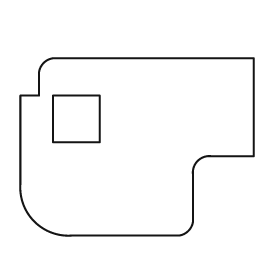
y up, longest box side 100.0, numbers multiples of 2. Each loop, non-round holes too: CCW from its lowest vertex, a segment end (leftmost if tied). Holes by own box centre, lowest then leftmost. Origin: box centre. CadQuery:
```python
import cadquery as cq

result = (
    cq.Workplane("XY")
    .moveTo(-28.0, -38.0)
    .lineTo(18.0, -38.0)
    .threePointArc((22.0, -36.0), (24.0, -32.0))
    .lineTo(24.0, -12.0)
    .threePointArc((26.0, -6.0), (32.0, -4.0))
    .lineTo(50.0, -4.0)
    .lineTo(50.0, 38.0)
    .lineTo(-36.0, 38.0)
    .threePointArc((-40.0, 36.0), (-42.0, 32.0))
    .lineTo(-42.0, 22.0)
    .lineTo(-50.0, 22.0)
    .lineTo(-50.0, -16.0)
    .threePointArc((-44.0, -32.0), (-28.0, -38.0))
    .close()
    .moveTo(-36.0, 2.0)
    .lineTo(-16.0, 2.0)
    .lineTo(-16.0, 22.0)
    .lineTo(-36.0, 22.0)
    .close()
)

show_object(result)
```